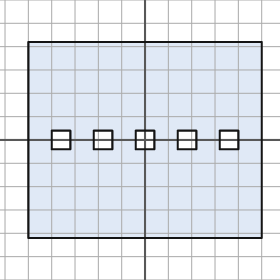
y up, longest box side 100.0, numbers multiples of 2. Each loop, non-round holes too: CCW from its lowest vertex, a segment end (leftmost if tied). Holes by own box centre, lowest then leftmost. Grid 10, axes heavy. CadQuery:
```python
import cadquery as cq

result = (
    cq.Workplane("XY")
    .moveTo(-50.0, -42.0)
    .lineTo(50.0, -42.0)
    .lineTo(50.0, 42.0)
    .lineTo(-50.0, 42.0)
    .close()
    .moveTo(-40.0, -4.0)
    .lineTo(-32.0, -4.0)
    .lineTo(-32.0, 4.0)
    .lineTo(-40.0, 4.0)
    .close()
    .moveTo(-22.0, -4.0)
    .lineTo(-14.0, -4.0)
    .lineTo(-14.0, 4.0)
    .lineTo(-22.0, 4.0)
    .close()
    .moveTo(-4.0, -4.0)
    .lineTo(4.0, -4.0)
    .lineTo(4.0, 4.0)
    .lineTo(-4.0, 4.0)
    .close()
    .moveTo(14.0, -4.0)
    .lineTo(22.0, -4.0)
    .lineTo(22.0, 4.0)
    .lineTo(14.0, 4.0)
    .close()
    .moveTo(32.0, -4.0)
    .lineTo(40.0, -4.0)
    .lineTo(40.0, 4.0)
    .lineTo(32.0, 4.0)
    .close()
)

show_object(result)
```